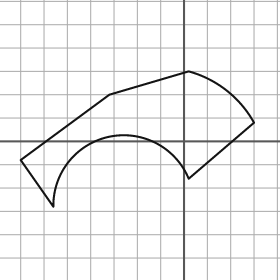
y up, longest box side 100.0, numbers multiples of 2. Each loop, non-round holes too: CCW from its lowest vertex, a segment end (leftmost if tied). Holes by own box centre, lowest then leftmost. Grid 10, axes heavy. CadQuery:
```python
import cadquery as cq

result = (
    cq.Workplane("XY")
    .moveTo(-56.0, -28.0)
    .threePointArc((-32.0, 2.0), (2.0, -16.0))
    .lineTo(30.0, 8.0)
    .threePointArc((18.0, 22.0), (2.0, 30.0))
    .lineTo(-32.0, 20.0)
    .lineTo(-70.0, -8.0)
    .close()
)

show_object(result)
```